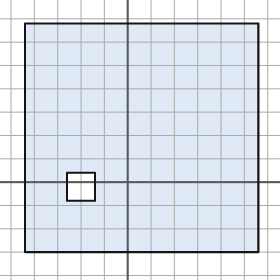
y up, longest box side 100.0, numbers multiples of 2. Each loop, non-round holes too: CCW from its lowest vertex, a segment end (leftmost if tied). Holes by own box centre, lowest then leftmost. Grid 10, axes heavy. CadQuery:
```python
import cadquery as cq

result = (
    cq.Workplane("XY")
    .moveTo(-44.0, -30.0)
    .lineTo(56.0, -30.0)
    .lineTo(56.0, 68.0)
    .lineTo(-44.0, 68.0)
    .close()
    .moveTo(-26.0, -8.0)
    .lineTo(-14.0, -8.0)
    .lineTo(-14.0, 4.0)
    .lineTo(-26.0, 4.0)
    .close()
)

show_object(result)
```